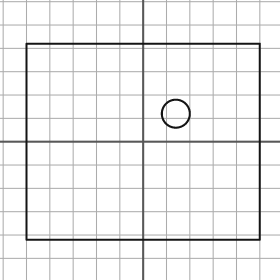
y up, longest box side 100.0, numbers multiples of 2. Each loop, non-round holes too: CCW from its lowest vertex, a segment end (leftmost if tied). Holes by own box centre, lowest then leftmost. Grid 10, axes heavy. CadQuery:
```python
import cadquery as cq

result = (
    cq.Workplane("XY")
    .moveTo(-50.0, -42.0)
    .lineTo(50.0, -42.0)
    .lineTo(50.0, 42.0)
    .lineTo(-50.0, 42.0)
    .close()
    .moveTo(14.0, 12.0)
    .circle(6.0)
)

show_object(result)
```